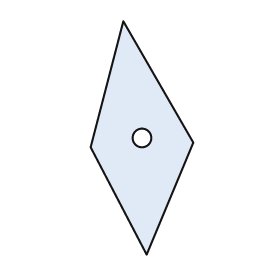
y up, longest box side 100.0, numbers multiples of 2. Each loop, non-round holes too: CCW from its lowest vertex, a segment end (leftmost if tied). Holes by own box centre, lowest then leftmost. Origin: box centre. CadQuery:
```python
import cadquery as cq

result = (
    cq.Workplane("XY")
    .moveTo(2.0, -50.0)
    .lineTo(22.0, -2.0)
    .lineTo(-8.0, 50.0)
    .lineTo(-22.0, -4.0)
    .close()
    .moveTo(0.0, 0.0)
    .circle(4.0)
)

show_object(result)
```